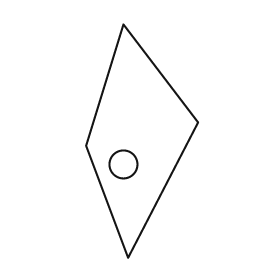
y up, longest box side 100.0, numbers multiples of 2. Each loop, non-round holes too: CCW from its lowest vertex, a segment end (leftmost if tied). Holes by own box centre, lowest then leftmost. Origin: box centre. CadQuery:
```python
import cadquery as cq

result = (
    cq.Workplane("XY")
    .moveTo(-6.0, -50.0)
    .lineTo(24.0, 8.0)
    .lineTo(-8.0, 50.0)
    .lineTo(-24.0, -2.0)
    .close()
    .moveTo(-8.0, -10.0)
    .circle(6.0)
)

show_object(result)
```